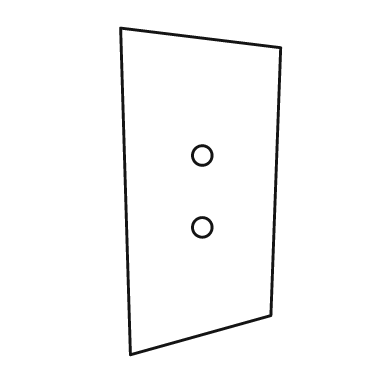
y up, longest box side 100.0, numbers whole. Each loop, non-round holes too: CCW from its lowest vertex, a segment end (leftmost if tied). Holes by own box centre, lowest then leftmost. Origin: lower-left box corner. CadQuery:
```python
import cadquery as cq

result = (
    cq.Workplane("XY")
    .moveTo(3.0, 0.0)
    .lineTo(46.0, 12.0)
    .lineTo(49.0, 94.0)
    .lineTo(0.0, 100.0)
    .close()
    .moveTo(25.0, 39.0)
    .circle(3.0)
    .moveTo(25.0, 61.0)
    .circle(3.0)
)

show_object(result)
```